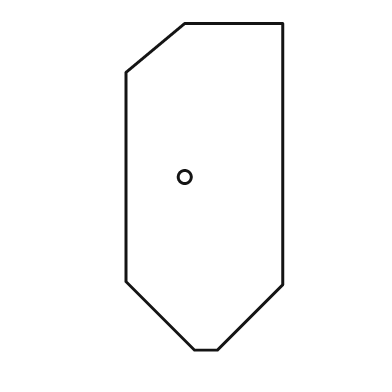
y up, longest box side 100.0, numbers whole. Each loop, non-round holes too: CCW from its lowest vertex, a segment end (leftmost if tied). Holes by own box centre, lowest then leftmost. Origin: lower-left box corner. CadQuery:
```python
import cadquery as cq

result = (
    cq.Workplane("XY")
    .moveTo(21.0, 0.0)
    .lineTo(28.0, 0.0)
    .lineTo(48.0, 20.0)
    .lineTo(48.0, 100.0)
    .lineTo(18.0, 100.0)
    .lineTo(0.0, 85.0)
    .lineTo(0.0, 21.0)
    .close()
    .moveTo(18.0, 53.0)
    .circle(2.0)
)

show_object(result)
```